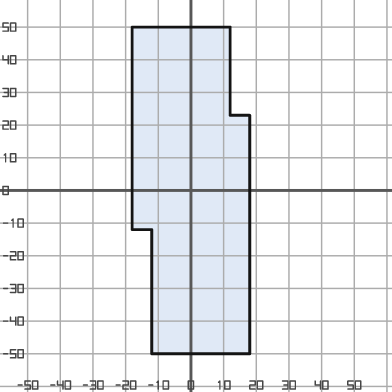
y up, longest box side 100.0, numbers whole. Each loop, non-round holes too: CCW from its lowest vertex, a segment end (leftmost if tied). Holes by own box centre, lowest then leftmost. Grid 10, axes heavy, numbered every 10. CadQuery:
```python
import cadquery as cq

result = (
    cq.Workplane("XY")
    .moveTo(-12.0, -50.0)
    .lineTo(18.0, -50.0)
    .lineTo(18.0, 23.0)
    .lineTo(12.0, 23.0)
    .lineTo(12.0, 50.0)
    .lineTo(-18.0, 50.0)
    .lineTo(-18.0, -12.0)
    .lineTo(-12.0, -12.0)
    .close()
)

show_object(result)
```